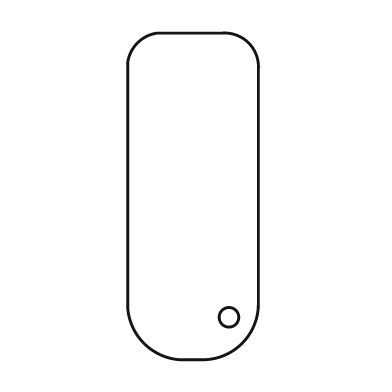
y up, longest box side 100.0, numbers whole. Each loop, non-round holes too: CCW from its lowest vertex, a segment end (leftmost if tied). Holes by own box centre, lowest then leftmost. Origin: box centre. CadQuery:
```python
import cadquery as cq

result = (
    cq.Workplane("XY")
    .moveTo(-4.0, -50.0)
    .lineTo(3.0, -50.0)
    .threePointArc((15.0, -45.0), (20.0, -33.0))
    .lineTo(20.0, 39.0)
    .threePointArc((17.0, 47.0), (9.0, 50.0))
    .lineTo(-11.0, 50.0)
    .threePointArc((-17.0, 47.0), (-20.0, 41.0))
    .lineTo(-20.0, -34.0)
    .threePointArc((-15.0, -45.0), (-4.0, -50.0))
    .close()
    .moveTo(11.0, -37.0)
    .circle(3.0)
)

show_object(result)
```